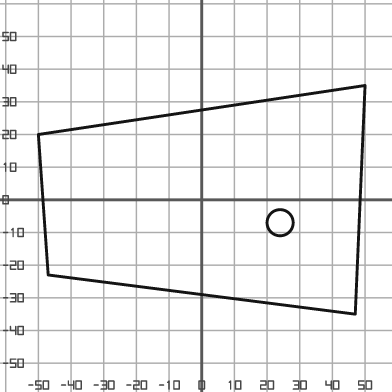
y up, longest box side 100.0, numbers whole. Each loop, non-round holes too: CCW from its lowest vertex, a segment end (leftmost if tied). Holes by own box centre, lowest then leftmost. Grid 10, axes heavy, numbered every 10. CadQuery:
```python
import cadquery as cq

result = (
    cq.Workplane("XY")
    .moveTo(47.0, -35.0)
    .lineTo(50.0, 35.0)
    .lineTo(-50.0, 20.0)
    .lineTo(-47.0, -23.0)
    .close()
    .moveTo(24.0, -7.0)
    .circle(4.0)
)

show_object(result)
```